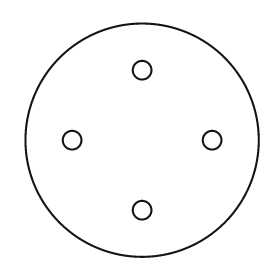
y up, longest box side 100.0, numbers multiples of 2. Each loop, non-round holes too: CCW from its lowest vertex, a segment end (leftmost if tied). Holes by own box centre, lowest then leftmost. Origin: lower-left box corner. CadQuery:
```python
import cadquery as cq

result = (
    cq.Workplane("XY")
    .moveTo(50.0, 50.0)
    .circle(50.0)
    .moveTo(50.0, 20.0)
    .circle(4.0)
    .moveTo(20.0, 50.0)
    .circle(4.0)
    .moveTo(80.0, 50.0)
    .circle(4.0)
    .moveTo(50.0, 80.0)
    .circle(4.0)
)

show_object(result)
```